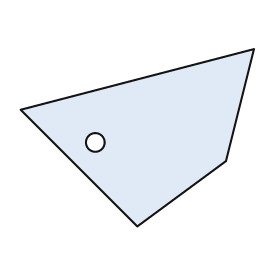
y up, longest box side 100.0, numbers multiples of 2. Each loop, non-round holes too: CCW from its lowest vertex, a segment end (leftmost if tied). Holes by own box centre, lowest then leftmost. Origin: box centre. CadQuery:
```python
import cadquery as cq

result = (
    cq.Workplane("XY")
    .moveTo(0.0, -38.0)
    .lineTo(38.0, -10.0)
    .lineTo(50.0, 38.0)
    .lineTo(-50.0, 12.0)
    .close()
    .moveTo(-18.0, -2.0)
    .circle(4.0)
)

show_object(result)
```